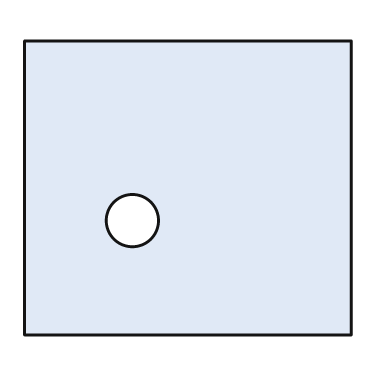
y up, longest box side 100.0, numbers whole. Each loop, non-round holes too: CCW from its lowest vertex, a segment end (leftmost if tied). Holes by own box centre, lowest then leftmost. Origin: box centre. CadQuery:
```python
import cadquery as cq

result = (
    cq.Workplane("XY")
    .moveTo(-50.0, -45.0)
    .lineTo(50.0, -45.0)
    .lineTo(50.0, 45.0)
    .lineTo(-50.0, 45.0)
    .close()
    .moveTo(-17.0, -10.0)
    .circle(8.0)
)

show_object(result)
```